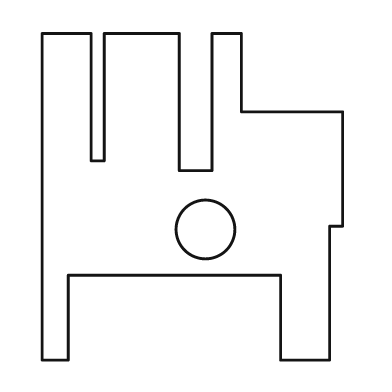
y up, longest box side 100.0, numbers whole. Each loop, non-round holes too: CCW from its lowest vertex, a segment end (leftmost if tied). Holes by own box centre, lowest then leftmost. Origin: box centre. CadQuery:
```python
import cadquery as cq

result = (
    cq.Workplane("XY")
    .moveTo(-46.0, -50.0)
    .lineTo(-38.0, -50.0)
    .lineTo(-38.0, -24.0)
    .lineTo(27.0, -24.0)
    .lineTo(27.0, -50.0)
    .lineTo(42.0, -50.0)
    .lineTo(42.0, -9.0)
    .lineTo(46.0, -9.0)
    .lineTo(46.0, 26.0)
    .lineTo(15.0, 26.0)
    .lineTo(15.0, 50.0)
    .lineTo(6.0, 50.0)
    .lineTo(6.0, 8.0)
    .lineTo(-4.0, 8.0)
    .lineTo(-4.0, 50.0)
    .lineTo(-27.0, 50.0)
    .lineTo(-27.0, 11.0)
    .lineTo(-31.0, 11.0)
    .lineTo(-31.0, 50.0)
    .lineTo(-46.0, 50.0)
    .close()
    .moveTo(4.0, -10.0)
    .circle(9.0)
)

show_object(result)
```